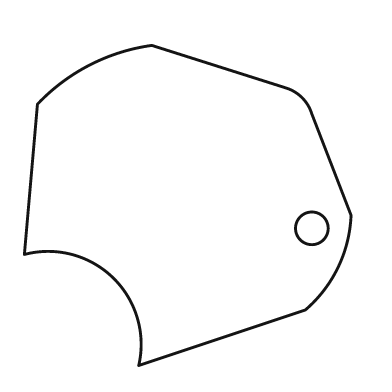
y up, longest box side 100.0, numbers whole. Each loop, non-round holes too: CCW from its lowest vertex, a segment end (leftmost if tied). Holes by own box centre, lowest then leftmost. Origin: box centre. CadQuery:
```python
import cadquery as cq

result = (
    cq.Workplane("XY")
    .moveTo(-15.0, -49.0)
    .lineTo(36.0, -32.0)
    .threePointArc((46.0, -19.0), (50.0, -3.0))
    .lineTo(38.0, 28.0)
    .threePointArc((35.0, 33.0), (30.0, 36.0))
    .lineTo(-11.0, 49.0)
    .threePointArc((-30.0, 43.0), (-46.0, 31.0))
    .lineTo(-50.0, -15.0)
    .threePointArc((-23.0, -22.0), (-15.0, -49.0))
    .close()
    .moveTo(38.0, -7.0)
    .circle(5.0)
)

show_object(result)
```